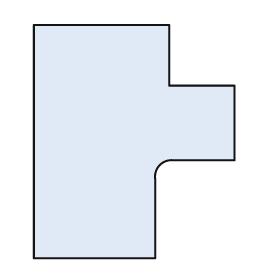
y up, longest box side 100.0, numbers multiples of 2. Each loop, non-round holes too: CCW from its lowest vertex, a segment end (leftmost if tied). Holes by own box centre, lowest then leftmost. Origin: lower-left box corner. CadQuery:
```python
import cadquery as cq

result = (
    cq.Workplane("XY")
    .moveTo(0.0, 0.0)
    .lineTo(52.0, 0.0)
    .lineTo(52.0, 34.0)
    .threePointArc((54.0, 40.0), (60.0, 42.0))
    .lineTo(86.0, 42.0)
    .lineTo(86.0, 74.0)
    .lineTo(58.0, 74.0)
    .lineTo(58.0, 100.0)
    .lineTo(0.0, 100.0)
    .close()
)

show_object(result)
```